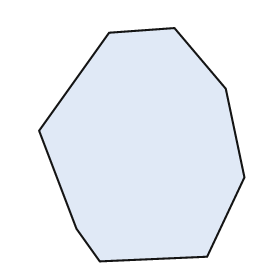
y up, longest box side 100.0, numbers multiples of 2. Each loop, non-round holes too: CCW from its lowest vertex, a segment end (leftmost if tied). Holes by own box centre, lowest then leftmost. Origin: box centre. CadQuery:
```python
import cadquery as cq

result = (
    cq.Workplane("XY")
    .moveTo(-18.0, -50.0)
    .lineTo(28.0, -48.0)
    .lineTo(44.0, -14.0)
    .lineTo(36.0, 24.0)
    .lineTo(14.0, 50.0)
    .lineTo(-14.0, 48.0)
    .lineTo(-44.0, 6.0)
    .lineTo(-28.0, -36.0)
    .close()
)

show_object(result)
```